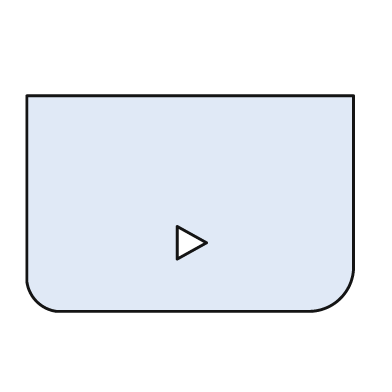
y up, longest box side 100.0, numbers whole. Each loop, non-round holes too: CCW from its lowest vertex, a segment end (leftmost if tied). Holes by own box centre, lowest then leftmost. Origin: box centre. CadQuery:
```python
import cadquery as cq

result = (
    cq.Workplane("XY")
    .moveTo(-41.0, -33.0)
    .lineTo(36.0, -33.0)
    .threePointArc((46.0, -29.0), (50.0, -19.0))
    .lineTo(50.0, 33.0)
    .lineTo(-50.0, 33.0)
    .lineTo(-50.0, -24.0)
    .threePointArc((-47.0, -30.0), (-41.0, -33.0))
    .close()
    .moveTo(-4.0, -17.0)
    .lineTo(5.0, -12.0)
    .lineTo(-4.0, -7.0)
    .close()
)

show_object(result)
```